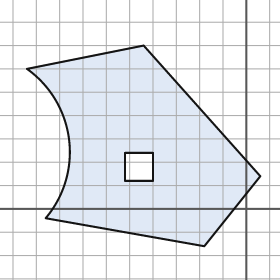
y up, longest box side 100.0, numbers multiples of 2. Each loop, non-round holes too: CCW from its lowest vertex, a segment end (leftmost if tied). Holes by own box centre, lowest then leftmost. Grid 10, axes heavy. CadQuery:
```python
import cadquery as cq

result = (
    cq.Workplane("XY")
    .moveTo(-18.0, -16.0)
    .lineTo(6.0, 14.0)
    .lineTo(-44.0, 70.0)
    .lineTo(-94.0, 60.0)
    .threePointArc((-76.0, 30.0), (-86.0, -4.0))
    .close()
    .moveTo(-52.0, 12.0)
    .lineTo(-40.0, 12.0)
    .lineTo(-40.0, 24.0)
    .lineTo(-52.0, 24.0)
    .close()
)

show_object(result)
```